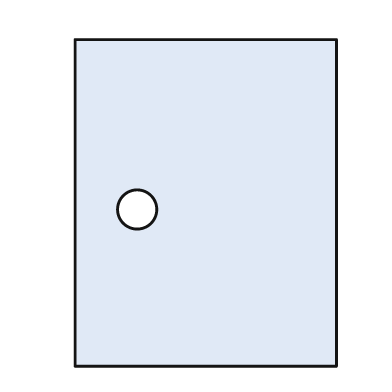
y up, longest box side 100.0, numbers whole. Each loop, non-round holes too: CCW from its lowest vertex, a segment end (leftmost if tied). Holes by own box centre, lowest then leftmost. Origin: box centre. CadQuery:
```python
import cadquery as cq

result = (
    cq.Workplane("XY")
    .moveTo(-40.0, -50.0)
    .lineTo(40.0, -50.0)
    .lineTo(40.0, 50.0)
    .lineTo(-40.0, 50.0)
    .close()
    .moveTo(-21.0, -2.0)
    .circle(6.0)
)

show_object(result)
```